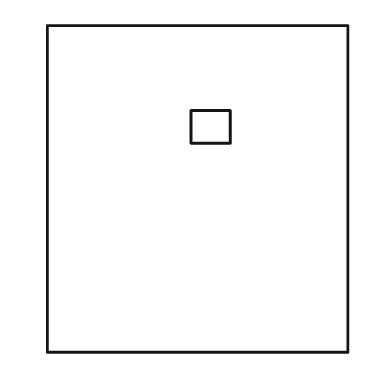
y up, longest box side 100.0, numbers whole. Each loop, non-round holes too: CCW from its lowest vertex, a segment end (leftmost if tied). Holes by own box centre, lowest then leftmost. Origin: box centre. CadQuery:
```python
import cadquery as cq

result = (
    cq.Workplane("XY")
    .moveTo(-46.0, -50.0)
    .lineTo(46.0, -50.0)
    .lineTo(46.0, 50.0)
    .lineTo(-46.0, 50.0)
    .close()
    .moveTo(-2.0, 14.0)
    .lineTo(10.0, 14.0)
    .lineTo(10.0, 24.0)
    .lineTo(-2.0, 24.0)
    .close()
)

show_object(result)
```